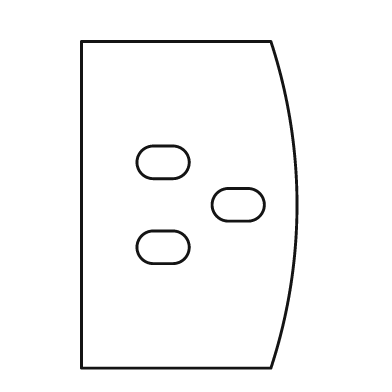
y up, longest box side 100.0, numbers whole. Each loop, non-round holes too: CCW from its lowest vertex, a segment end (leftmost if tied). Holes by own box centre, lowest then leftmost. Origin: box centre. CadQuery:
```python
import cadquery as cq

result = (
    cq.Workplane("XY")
    .moveTo(-33.0, -50.0)
    .lineTo(25.0, -50.0)
    .threePointArc((33.0, 0.0), (25.0, 50.0))
    .lineTo(-33.0, 50.0)
    .close()
    .moveTo(-11.0, -18.0)
    .lineTo(-5.0, -18.0)
    .threePointArc((0.0, -13.0), (-5.0, -8.0))
    .lineTo(-11.0, -8.0)
    .threePointArc((-16.0, -13.0), (-11.0, -18.0))
    .close()
    .moveTo(12.0, -5.0)
    .lineTo(18.0, -5.0)
    .threePointArc((23.0, 0.0), (18.0, 5.0))
    .lineTo(12.0, 5.0)
    .threePointArc((7.0, 0.0), (12.0, -5.0))
    .close()
    .moveTo(-11.0, 8.0)
    .lineTo(-5.0, 8.0)
    .threePointArc((0.0, 13.0), (-5.0, 18.0))
    .lineTo(-11.0, 18.0)
    .threePointArc((-16.0, 13.0), (-11.0, 8.0))
    .close()
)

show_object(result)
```